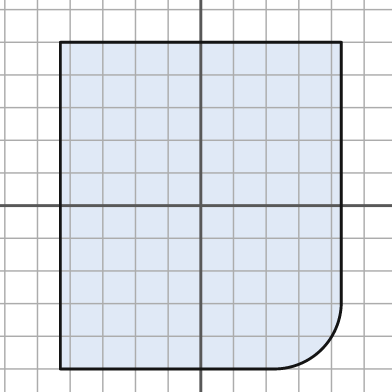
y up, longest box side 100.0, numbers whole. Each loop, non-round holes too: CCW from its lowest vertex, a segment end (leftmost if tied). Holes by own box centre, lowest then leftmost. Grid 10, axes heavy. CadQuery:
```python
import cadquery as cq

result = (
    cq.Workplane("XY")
    .moveTo(-43.0, -50.0)
    .lineTo(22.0, -50.0)
    .threePointArc((37.0, -44.0), (43.0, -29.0))
    .lineTo(43.0, 50.0)
    .lineTo(-43.0, 50.0)
    .close()
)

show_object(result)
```